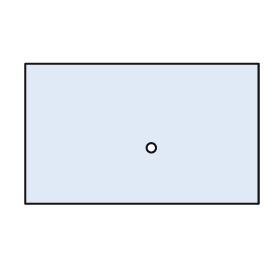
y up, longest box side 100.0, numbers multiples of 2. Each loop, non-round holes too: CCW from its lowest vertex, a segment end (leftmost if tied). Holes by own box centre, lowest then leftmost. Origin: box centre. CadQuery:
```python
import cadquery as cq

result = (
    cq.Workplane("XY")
    .moveTo(-50.0, -30.0)
    .lineTo(50.0, -30.0)
    .lineTo(50.0, 30.0)
    .lineTo(-50.0, 30.0)
    .close()
    .moveTo(4.0, -6.0)
    .circle(2.0)
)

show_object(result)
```